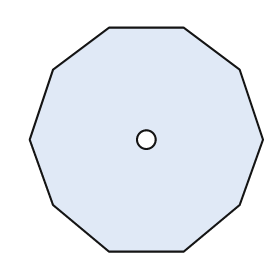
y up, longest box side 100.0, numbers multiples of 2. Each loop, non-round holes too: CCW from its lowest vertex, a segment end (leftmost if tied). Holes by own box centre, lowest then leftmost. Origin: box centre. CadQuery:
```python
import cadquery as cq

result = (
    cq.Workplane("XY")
    .moveTo(-16.0, -48.0)
    .lineTo(16.0, -48.0)
    .lineTo(40.0, -28.0)
    .lineTo(50.0, 0.0)
    .lineTo(40.0, 30.0)
    .lineTo(16.0, 48.0)
    .lineTo(-16.0, 48.0)
    .lineTo(-40.0, 30.0)
    .lineTo(-50.0, 0.0)
    .lineTo(-40.0, -28.0)
    .close()
    .moveTo(0.0, 0.0)
    .circle(4.0)
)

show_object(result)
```